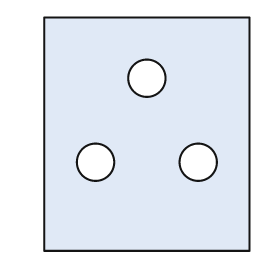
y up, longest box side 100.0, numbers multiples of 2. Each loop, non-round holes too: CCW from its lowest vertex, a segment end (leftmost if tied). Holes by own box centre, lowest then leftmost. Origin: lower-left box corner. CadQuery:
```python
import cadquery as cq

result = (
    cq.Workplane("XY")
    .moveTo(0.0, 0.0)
    .lineTo(88.0, 0.0)
    .lineTo(88.0, 100.0)
    .lineTo(0.0, 100.0)
    .close()
    .moveTo(22.0, 38.0)
    .circle(8.0)
    .moveTo(66.0, 38.0)
    .circle(8.0)
    .moveTo(44.0, 74.0)
    .circle(8.0)
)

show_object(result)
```